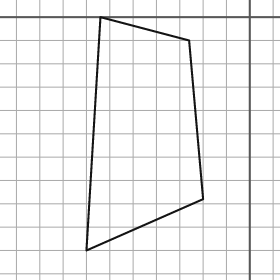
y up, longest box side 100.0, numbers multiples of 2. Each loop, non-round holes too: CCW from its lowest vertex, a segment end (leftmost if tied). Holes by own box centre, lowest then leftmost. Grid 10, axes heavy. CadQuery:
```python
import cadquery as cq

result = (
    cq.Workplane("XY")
    .moveTo(-70.0, -100.0)
    .lineTo(-20.0, -78.0)
    .lineTo(-26.0, -10.0)
    .lineTo(-64.0, 0.0)
    .close()
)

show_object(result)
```